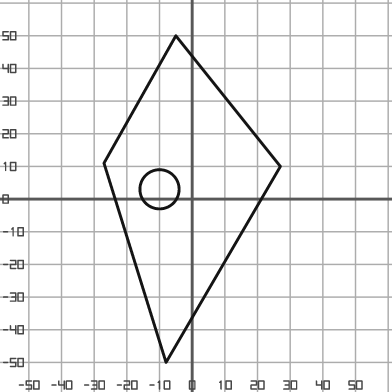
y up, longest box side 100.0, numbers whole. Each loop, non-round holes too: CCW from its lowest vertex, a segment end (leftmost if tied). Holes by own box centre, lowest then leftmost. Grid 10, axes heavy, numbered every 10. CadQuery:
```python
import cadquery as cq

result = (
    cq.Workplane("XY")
    .moveTo(-8.0, -50.0)
    .lineTo(27.0, 10.0)
    .lineTo(-5.0, 50.0)
    .lineTo(-27.0, 11.0)
    .close()
    .moveTo(-10.0, 3.0)
    .circle(6.0)
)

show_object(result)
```